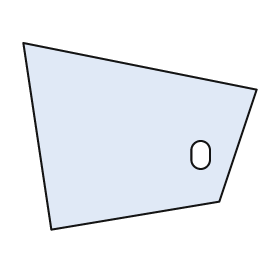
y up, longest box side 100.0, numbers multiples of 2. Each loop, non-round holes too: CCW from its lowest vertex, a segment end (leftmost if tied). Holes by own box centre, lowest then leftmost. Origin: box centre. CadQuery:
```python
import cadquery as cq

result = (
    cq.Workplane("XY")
    .moveTo(-38.0, -40.0)
    .lineTo(34.0, -28.0)
    .lineTo(50.0, 20.0)
    .lineTo(-50.0, 40.0)
    .close()
    .moveTo(22.0, -10.0)
    .threePointArc((26.0, -14.0), (30.0, -10.0))
    .lineTo(30.0, -6.0)
    .threePointArc((26.0, -2.0), (22.0, -6.0))
    .close()
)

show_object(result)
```